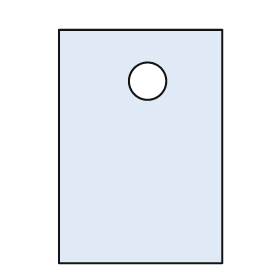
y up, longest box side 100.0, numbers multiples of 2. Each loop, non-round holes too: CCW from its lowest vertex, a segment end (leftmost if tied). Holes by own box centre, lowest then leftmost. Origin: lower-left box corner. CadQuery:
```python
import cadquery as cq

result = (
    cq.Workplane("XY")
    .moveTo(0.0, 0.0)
    .lineTo(70.0, 0.0)
    .lineTo(70.0, 100.0)
    .lineTo(0.0, 100.0)
    .close()
    .moveTo(38.0, 78.0)
    .circle(8.0)
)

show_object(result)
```